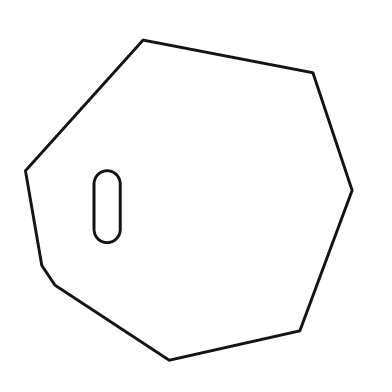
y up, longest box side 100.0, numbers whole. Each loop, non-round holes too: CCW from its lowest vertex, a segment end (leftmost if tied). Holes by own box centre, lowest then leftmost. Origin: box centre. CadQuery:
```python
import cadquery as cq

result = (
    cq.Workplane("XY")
    .moveTo(-6.0, -49.0)
    .lineTo(34.0, -40.0)
    .lineTo(50.0, 3.0)
    .lineTo(38.0, 39.0)
    .lineTo(-14.0, 49.0)
    .lineTo(-50.0, 9.0)
    .lineTo(-45.0, -20.0)
    .lineTo(-41.0, -26.0)
    .close()
    .moveTo(-29.0, -9.0)
    .threePointArc((-25.0, -13.0), (-21.0, -9.0))
    .lineTo(-21.0, 5.0)
    .threePointArc((-25.0, 9.0), (-29.0, 5.0))
    .close()
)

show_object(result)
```